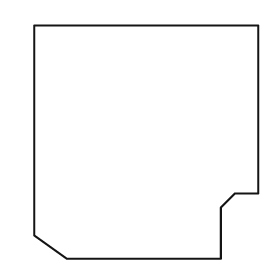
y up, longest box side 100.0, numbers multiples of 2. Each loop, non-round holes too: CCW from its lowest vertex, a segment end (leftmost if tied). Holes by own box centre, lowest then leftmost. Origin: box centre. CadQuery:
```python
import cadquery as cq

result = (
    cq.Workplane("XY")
    .moveTo(-34.0, -50.0)
    .lineTo(32.0, -50.0)
    .lineTo(32.0, -28.0)
    .lineTo(38.0, -22.0)
    .lineTo(48.0, -22.0)
    .lineTo(48.0, 50.0)
    .lineTo(-48.0, 50.0)
    .lineTo(-48.0, -40.0)
    .close()
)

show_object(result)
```